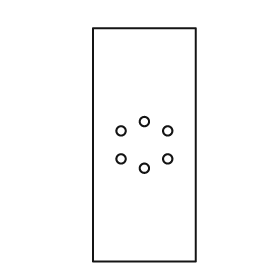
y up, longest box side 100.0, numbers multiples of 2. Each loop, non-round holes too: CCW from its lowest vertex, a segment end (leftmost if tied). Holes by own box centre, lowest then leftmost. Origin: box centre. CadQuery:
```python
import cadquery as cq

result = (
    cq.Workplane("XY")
    .moveTo(-22.0, -50.0)
    .lineTo(22.0, -50.0)
    .lineTo(22.0, 50.0)
    .lineTo(-22.0, 50.0)
    .close()
    .moveTo(0.0, -10.0)
    .circle(2.0)
    .moveTo(-10.0, -6.0)
    .circle(2.0)
    .moveTo(10.0, -6.0)
    .circle(2.0)
    .moveTo(-10.0, 6.0)
    .circle(2.0)
    .moveTo(10.0, 6.0)
    .circle(2.0)
    .moveTo(0.0, 10.0)
    .circle(2.0)
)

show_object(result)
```